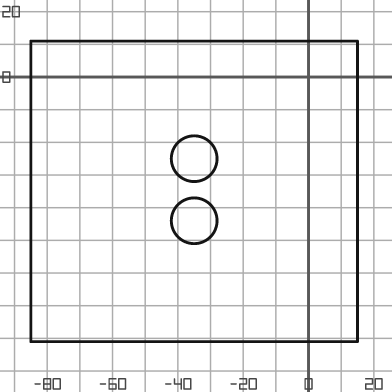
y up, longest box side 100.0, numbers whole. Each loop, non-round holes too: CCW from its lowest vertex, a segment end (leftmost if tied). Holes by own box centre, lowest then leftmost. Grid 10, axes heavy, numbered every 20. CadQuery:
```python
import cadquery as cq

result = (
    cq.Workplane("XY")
    .moveTo(-85.0, -81.0)
    .lineTo(15.0, -81.0)
    .lineTo(15.0, 11.0)
    .lineTo(-85.0, 11.0)
    .close()
    .moveTo(-35.0, -44.0)
    .circle(7.0)
    .moveTo(-35.0, -25.0)
    .circle(7.0)
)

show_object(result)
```